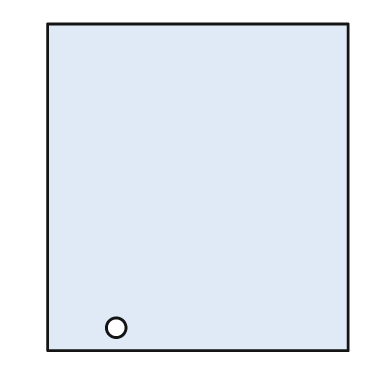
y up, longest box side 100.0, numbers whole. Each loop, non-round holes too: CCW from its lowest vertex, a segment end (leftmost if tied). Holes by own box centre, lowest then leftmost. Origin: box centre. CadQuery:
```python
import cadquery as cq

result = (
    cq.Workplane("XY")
    .moveTo(-46.0, -50.0)
    .lineTo(46.0, -50.0)
    .lineTo(46.0, 50.0)
    .lineTo(-46.0, 50.0)
    .close()
    .moveTo(-25.0, -43.0)
    .circle(3.0)
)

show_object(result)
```